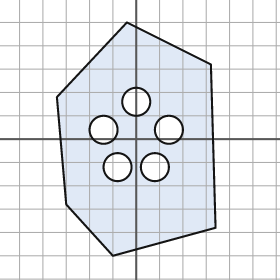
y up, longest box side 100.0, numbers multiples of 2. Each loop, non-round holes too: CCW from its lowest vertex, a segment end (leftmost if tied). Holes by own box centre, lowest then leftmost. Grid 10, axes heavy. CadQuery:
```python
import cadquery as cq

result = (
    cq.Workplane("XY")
    .moveTo(-10.0, -50.0)
    .lineTo(34.0, -38.0)
    .lineTo(32.0, 32.0)
    .lineTo(-4.0, 50.0)
    .lineTo(-34.0, 18.0)
    .lineTo(-30.0, -28.0)
    .close()
    .moveTo(-8.0, -12.0)
    .circle(6.0)
    .moveTo(8.0, -12.0)
    .circle(6.0)
    .moveTo(-14.0, 4.0)
    .circle(6.0)
    .moveTo(14.0, 4.0)
    .circle(6.0)
    .moveTo(0.0, 16.0)
    .circle(6.0)
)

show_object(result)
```